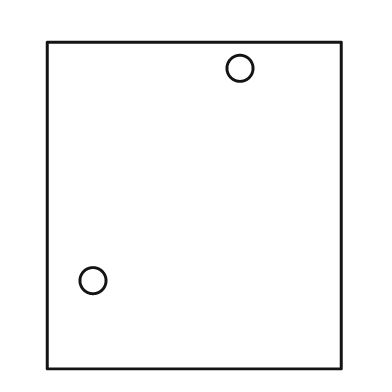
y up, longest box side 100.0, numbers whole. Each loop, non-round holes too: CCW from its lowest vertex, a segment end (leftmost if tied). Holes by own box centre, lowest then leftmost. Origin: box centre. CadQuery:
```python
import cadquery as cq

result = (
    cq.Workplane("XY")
    .moveTo(-45.0, -50.0)
    .lineTo(45.0, -50.0)
    .lineTo(45.0, 50.0)
    .lineTo(-45.0, 50.0)
    .close()
    .moveTo(-31.0, -23.0)
    .circle(4.0)
    .moveTo(14.0, 42.0)
    .circle(4.0)
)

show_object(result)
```